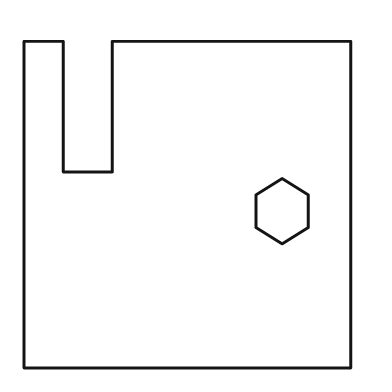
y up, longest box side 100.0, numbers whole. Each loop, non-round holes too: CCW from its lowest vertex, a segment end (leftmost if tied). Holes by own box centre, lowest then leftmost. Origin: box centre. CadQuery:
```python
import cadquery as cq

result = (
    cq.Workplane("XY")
    .moveTo(-50.0, -50.0)
    .lineTo(50.0, -50.0)
    .lineTo(50.0, 50.0)
    .lineTo(-23.0, 50.0)
    .lineTo(-23.0, 10.0)
    .lineTo(-38.0, 10.0)
    .lineTo(-38.0, 50.0)
    .lineTo(-50.0, 50.0)
    .close()
    .moveTo(29.0, -12.0)
    .lineTo(37.0, -7.0)
    .lineTo(37.0, 3.0)
    .lineTo(29.0, 8.0)
    .lineTo(21.0, 3.0)
    .lineTo(21.0, -7.0)
    .close()
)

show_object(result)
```